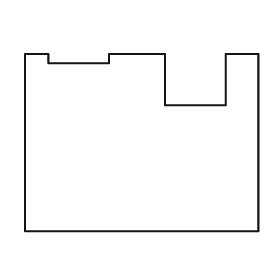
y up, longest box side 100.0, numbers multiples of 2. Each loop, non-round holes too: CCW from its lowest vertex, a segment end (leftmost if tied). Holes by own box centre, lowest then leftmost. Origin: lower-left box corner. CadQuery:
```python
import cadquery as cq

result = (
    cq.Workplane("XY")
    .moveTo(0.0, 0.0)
    .lineTo(100.0, 0.0)
    .lineTo(100.0, 76.0)
    .lineTo(86.0, 76.0)
    .lineTo(86.0, 54.0)
    .lineTo(60.0, 54.0)
    .lineTo(60.0, 76.0)
    .lineTo(36.0, 76.0)
    .lineTo(36.0, 72.0)
    .lineTo(10.0, 72.0)
    .lineTo(10.0, 76.0)
    .lineTo(0.0, 76.0)
    .close()
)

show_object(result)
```